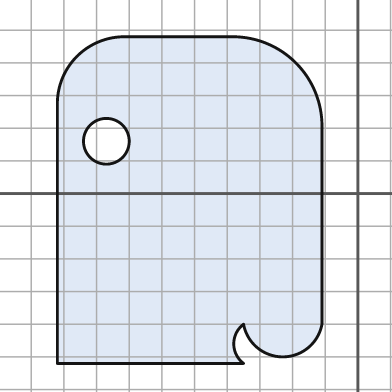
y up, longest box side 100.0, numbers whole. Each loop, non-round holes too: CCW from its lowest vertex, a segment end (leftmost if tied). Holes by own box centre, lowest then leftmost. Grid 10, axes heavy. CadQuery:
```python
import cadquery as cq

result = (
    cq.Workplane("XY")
    .moveTo(-92.0, -52.0)
    .lineTo(-35.0, -52.0)
    .threePointArc((-38.0, -46.0), (-35.0, -40.0))
    .threePointArc((-23.0, -50.0), (-11.0, -40.0))
    .lineTo(-11.0, 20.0)
    .threePointArc((-19.0, 40.0), (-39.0, 48.0))
    .lineTo(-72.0, 48.0)
    .threePointArc((-86.0, 42.0), (-92.0, 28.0))
    .close()
    .moveTo(-77.0, 16.0)
    .circle(7.0)
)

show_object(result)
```